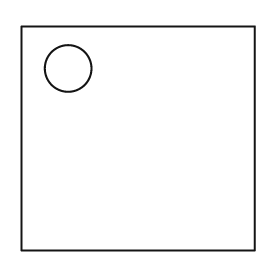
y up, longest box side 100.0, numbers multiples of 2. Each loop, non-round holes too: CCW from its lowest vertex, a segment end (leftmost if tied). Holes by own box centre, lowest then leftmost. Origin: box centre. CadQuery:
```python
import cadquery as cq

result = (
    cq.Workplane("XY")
    .moveTo(-50.0, -48.0)
    .lineTo(50.0, -48.0)
    .lineTo(50.0, 48.0)
    .lineTo(-50.0, 48.0)
    .close()
    .moveTo(-30.0, 30.0)
    .circle(10.0)
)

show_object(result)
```